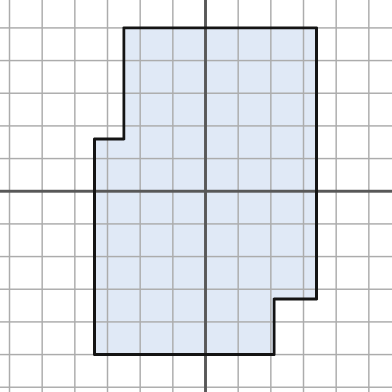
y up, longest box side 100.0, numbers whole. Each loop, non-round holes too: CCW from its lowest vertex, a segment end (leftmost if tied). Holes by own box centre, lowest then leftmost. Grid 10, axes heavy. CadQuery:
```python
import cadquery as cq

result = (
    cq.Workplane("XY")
    .moveTo(-34.0, -50.0)
    .lineTo(21.0, -50.0)
    .lineTo(21.0, -33.0)
    .lineTo(34.0, -33.0)
    .lineTo(34.0, 50.0)
    .lineTo(-25.0, 50.0)
    .lineTo(-25.0, 16.0)
    .lineTo(-34.0, 16.0)
    .close()
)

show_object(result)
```